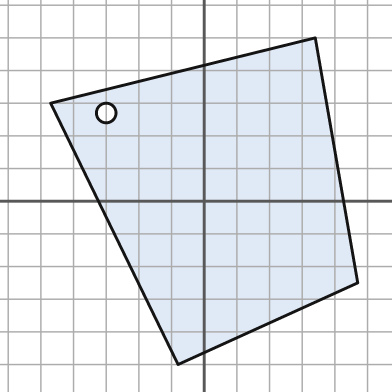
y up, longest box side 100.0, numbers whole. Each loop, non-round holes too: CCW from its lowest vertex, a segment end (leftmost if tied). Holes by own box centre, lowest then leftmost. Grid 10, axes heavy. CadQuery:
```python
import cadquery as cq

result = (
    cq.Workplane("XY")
    .moveTo(-8.0, -50.0)
    .lineTo(47.0, -25.0)
    .lineTo(34.0, 50.0)
    .lineTo(-47.0, 30.0)
    .close()
    .moveTo(-30.0, 27.0)
    .circle(3.0)
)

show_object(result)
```